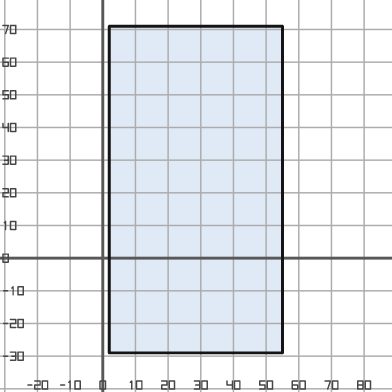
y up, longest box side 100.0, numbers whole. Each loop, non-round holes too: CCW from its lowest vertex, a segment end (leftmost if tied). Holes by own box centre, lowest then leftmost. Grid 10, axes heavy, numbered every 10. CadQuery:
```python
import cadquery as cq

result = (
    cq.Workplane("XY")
    .moveTo(2.0, -29.0)
    .lineTo(55.0, -29.0)
    .lineTo(55.0, 71.0)
    .lineTo(2.0, 71.0)
    .close()
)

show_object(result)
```